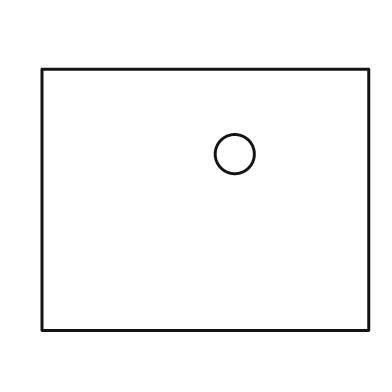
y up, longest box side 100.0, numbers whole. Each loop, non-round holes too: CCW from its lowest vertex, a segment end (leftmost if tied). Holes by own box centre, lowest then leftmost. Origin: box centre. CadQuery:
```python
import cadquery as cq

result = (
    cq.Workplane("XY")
    .moveTo(-50.0, -40.0)
    .lineTo(50.0, -40.0)
    .lineTo(50.0, 40.0)
    .lineTo(-50.0, 40.0)
    .close()
    .moveTo(9.0, 14.0)
    .circle(6.0)
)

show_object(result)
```